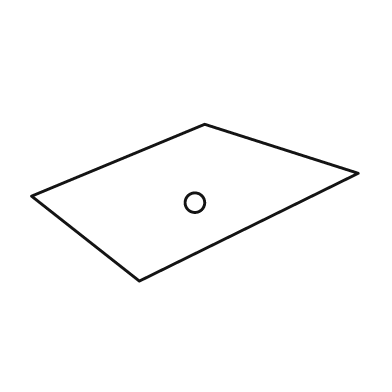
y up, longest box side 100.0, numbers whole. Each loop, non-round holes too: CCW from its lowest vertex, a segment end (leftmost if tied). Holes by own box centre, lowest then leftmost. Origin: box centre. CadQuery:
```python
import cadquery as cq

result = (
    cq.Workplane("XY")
    .moveTo(-17.0, -24.0)
    .lineTo(50.0, 9.0)
    .lineTo(3.0, 24.0)
    .lineTo(-50.0, 2.0)
    .close()
    .moveTo(0.0, 0.0)
    .circle(3.0)
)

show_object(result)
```